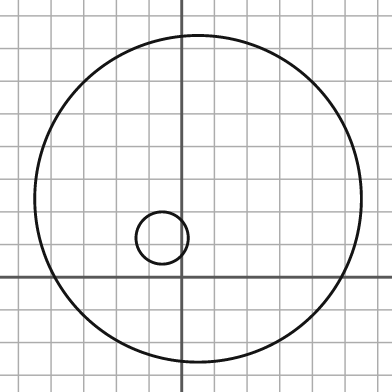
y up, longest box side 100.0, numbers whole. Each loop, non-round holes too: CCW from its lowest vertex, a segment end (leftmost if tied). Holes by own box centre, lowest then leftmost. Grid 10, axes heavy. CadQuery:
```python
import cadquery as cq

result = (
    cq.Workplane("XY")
    .moveTo(5.0, 24.0)
    .circle(50.0)
    .moveTo(-6.0, 12.0)
    .circle(8.0)
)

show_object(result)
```